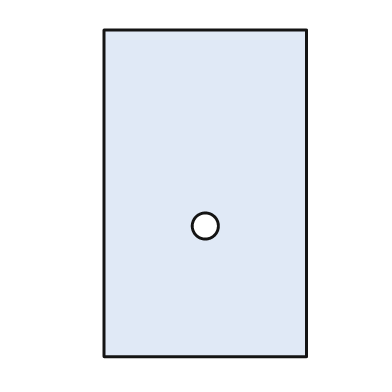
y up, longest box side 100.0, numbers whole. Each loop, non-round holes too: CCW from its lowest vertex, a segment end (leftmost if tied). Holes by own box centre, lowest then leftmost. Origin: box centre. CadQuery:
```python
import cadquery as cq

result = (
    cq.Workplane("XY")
    .moveTo(-31.0, -50.0)
    .lineTo(31.0, -50.0)
    .lineTo(31.0, 50.0)
    .lineTo(-31.0, 50.0)
    .close()
    .moveTo(0.0, -10.0)
    .circle(4.0)
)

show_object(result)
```